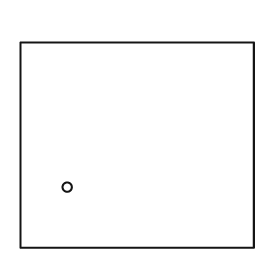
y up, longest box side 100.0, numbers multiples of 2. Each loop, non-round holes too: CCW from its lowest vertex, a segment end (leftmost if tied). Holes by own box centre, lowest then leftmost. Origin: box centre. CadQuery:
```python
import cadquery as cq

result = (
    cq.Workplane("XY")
    .moveTo(-50.0, -44.0)
    .lineTo(50.0, -44.0)
    .lineTo(50.0, 44.0)
    .lineTo(-50.0, 44.0)
    .close()
    .moveTo(-30.0, -18.0)
    .circle(2.0)
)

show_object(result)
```